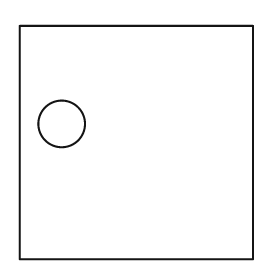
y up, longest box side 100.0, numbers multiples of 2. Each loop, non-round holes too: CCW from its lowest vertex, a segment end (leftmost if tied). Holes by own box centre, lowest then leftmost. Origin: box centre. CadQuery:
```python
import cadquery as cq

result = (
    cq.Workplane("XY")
    .moveTo(-50.0, -50.0)
    .lineTo(50.0, -50.0)
    .lineTo(50.0, 50.0)
    .lineTo(-50.0, 50.0)
    .close()
    .moveTo(-32.0, 8.0)
    .circle(10.0)
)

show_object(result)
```